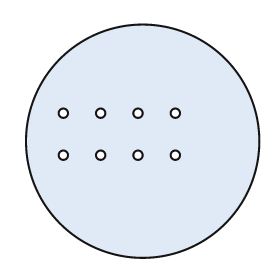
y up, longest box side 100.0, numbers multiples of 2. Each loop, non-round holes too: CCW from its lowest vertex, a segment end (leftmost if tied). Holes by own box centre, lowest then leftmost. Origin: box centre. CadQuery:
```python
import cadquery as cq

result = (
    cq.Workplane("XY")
    .moveTo(0.0, 0.0)
    .circle(50.0)
    .moveTo(-34.0, -6.0)
    .circle(2.0)
    .moveTo(-18.0, -6.0)
    .circle(2.0)
    .moveTo(-2.0, -6.0)
    .circle(2.0)
    .moveTo(14.0, -6.0)
    .circle(2.0)
    .moveTo(-34.0, 12.0)
    .circle(2.0)
    .moveTo(-18.0, 12.0)
    .circle(2.0)
    .moveTo(-2.0, 12.0)
    .circle(2.0)
    .moveTo(14.0, 12.0)
    .circle(2.0)
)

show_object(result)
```